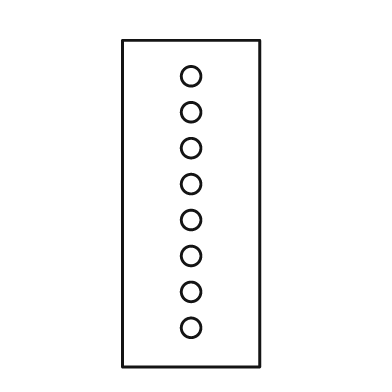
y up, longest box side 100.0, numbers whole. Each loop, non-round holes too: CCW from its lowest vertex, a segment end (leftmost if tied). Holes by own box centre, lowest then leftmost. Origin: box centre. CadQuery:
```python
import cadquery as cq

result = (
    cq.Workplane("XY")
    .moveTo(-21.0, -50.0)
    .lineTo(21.0, -50.0)
    .lineTo(21.0, 50.0)
    .lineTo(-21.0, 50.0)
    .close()
    .moveTo(0.0, -38.0)
    .circle(3.0)
    .moveTo(0.0, -27.0)
    .circle(3.0)
    .moveTo(0.0, -16.0)
    .circle(3.0)
    .moveTo(0.0, -5.0)
    .circle(3.0)
    .moveTo(0.0, 6.0)
    .circle(3.0)
    .moveTo(0.0, 17.0)
    .circle(3.0)
    .moveTo(0.0, 28.0)
    .circle(3.0)
    .moveTo(0.0, 39.0)
    .circle(3.0)
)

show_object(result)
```